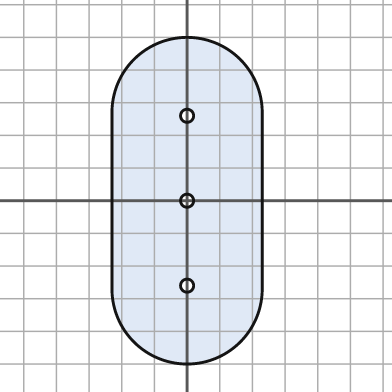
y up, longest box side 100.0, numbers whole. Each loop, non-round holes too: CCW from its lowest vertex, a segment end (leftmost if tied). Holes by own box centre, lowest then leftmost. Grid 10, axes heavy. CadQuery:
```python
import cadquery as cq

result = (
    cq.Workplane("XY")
    .moveTo(-23.0, -27.0)
    .threePointArc((0.0, -50.0), (23.0, -27.0))
    .lineTo(23.0, 27.0)
    .threePointArc((0.0, 50.0), (-23.0, 27.0))
    .close()
    .moveTo(0.0, -26.0)
    .circle(2.0)
    .moveTo(0.0, 0.0)
    .circle(2.0)
    .moveTo(0.0, 26.0)
    .circle(2.0)
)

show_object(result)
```